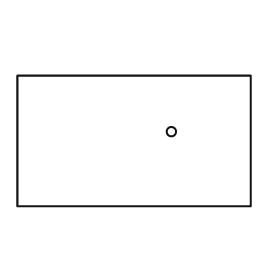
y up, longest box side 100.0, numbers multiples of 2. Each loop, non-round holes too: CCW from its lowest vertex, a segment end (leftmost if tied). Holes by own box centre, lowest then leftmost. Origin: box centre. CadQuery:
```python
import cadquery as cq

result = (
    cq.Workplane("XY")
    .moveTo(-50.0, -28.0)
    .lineTo(50.0, -28.0)
    .lineTo(50.0, 28.0)
    .lineTo(-50.0, 28.0)
    .close()
    .moveTo(16.0, 4.0)
    .circle(2.0)
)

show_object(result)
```